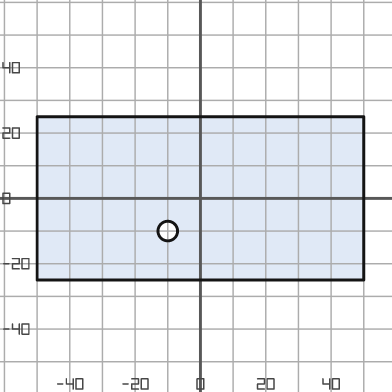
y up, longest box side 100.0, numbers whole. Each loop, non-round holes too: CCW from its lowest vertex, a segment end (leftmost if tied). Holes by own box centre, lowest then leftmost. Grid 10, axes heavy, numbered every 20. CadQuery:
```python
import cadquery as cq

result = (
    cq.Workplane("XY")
    .moveTo(-50.0, -25.0)
    .lineTo(50.0, -25.0)
    .lineTo(50.0, 25.0)
    .lineTo(-50.0, 25.0)
    .close()
    .moveTo(-10.0, -10.0)
    .circle(3.0)
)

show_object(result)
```